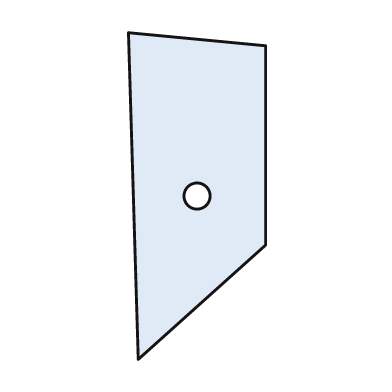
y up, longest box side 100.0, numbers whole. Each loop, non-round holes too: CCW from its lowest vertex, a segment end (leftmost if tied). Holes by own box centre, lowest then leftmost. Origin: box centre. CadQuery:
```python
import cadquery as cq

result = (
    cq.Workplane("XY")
    .moveTo(-18.0, -50.0)
    .lineTo(21.0, -15.0)
    .lineTo(21.0, 46.0)
    .lineTo(-21.0, 50.0)
    .close()
    .moveTo(0.0, 0.0)
    .circle(4.0)
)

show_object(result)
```